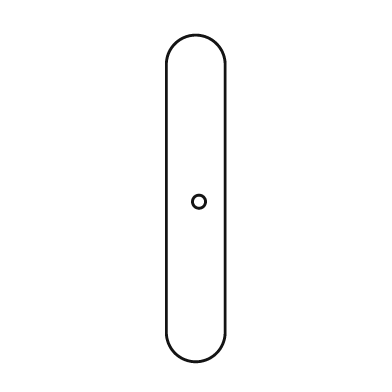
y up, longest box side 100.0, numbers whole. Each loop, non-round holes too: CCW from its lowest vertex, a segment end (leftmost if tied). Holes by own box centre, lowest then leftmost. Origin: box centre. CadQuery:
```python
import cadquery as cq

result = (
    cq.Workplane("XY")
    .moveTo(-9.0, -41.0)
    .threePointArc((0.0, -50.0), (9.0, -41.0))
    .lineTo(9.0, 41.0)
    .threePointArc((0.0, 50.0), (-9.0, 41.0))
    .close()
    .moveTo(1.0, -1.0)
    .circle(2.0)
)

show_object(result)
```